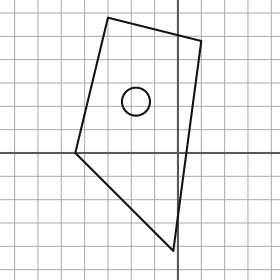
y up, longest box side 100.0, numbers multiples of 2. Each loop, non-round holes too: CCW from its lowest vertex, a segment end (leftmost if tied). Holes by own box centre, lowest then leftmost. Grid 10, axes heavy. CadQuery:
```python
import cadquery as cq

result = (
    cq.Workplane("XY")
    .moveTo(-2.0, -42.0)
    .lineTo(10.0, 48.0)
    .lineTo(-30.0, 58.0)
    .lineTo(-44.0, 0.0)
    .close()
    .moveTo(-18.0, 22.0)
    .circle(6.0)
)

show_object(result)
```